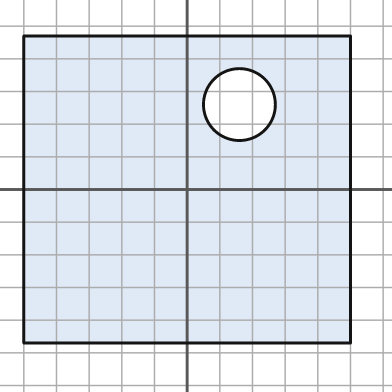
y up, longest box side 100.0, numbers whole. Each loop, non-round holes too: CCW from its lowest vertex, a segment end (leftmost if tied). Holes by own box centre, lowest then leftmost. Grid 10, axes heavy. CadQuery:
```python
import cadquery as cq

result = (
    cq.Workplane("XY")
    .moveTo(-50.0, -47.0)
    .lineTo(50.0, -47.0)
    .lineTo(50.0, 47.0)
    .lineTo(-50.0, 47.0)
    .close()
    .moveTo(16.0, 26.0)
    .circle(11.0)
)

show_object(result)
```